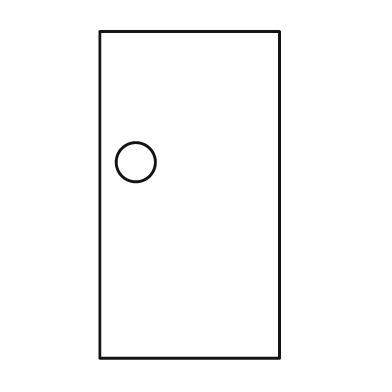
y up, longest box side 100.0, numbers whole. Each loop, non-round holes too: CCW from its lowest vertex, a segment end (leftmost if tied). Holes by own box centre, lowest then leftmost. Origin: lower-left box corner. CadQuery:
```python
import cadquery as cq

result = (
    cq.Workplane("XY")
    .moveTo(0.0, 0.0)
    .lineTo(55.0, 0.0)
    .lineTo(55.0, 100.0)
    .lineTo(0.0, 100.0)
    .close()
    .moveTo(11.0, 60.0)
    .circle(6.0)
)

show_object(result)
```